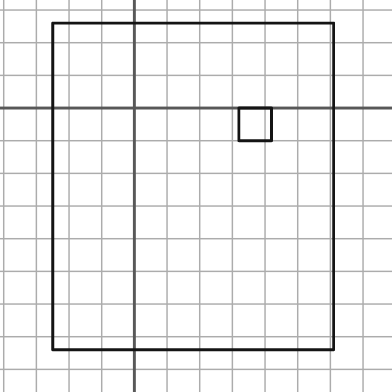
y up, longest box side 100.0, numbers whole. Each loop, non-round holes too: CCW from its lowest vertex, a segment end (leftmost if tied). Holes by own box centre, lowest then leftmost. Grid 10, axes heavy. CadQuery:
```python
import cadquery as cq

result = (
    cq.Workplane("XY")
    .moveTo(-25.0, -74.0)
    .lineTo(61.0, -74.0)
    .lineTo(61.0, 26.0)
    .lineTo(-25.0, 26.0)
    .close()
    .moveTo(32.0, -10.0)
    .lineTo(42.0, -10.0)
    .lineTo(42.0, 0.0)
    .lineTo(32.0, 0.0)
    .close()
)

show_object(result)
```